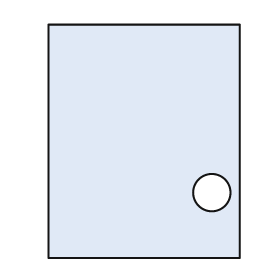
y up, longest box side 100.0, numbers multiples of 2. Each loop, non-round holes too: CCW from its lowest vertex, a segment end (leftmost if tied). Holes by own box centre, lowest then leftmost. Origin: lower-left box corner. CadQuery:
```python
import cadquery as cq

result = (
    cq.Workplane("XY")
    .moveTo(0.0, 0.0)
    .lineTo(82.0, 0.0)
    .lineTo(82.0, 100.0)
    .lineTo(0.0, 100.0)
    .close()
    .moveTo(70.0, 28.0)
    .circle(8.0)
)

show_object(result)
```